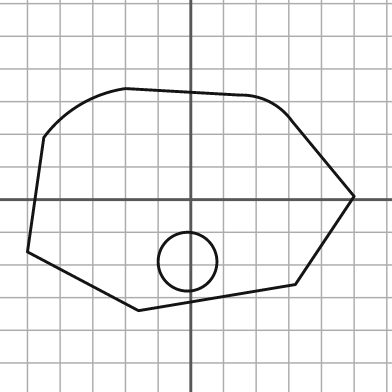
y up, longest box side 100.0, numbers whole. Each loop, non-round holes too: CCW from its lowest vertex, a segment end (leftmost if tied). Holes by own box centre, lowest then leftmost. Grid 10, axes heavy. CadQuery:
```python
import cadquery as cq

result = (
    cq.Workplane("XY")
    .moveTo(-16.0, -34.0)
    .lineTo(32.0, -26.0)
    .lineTo(50.0, 1.0)
    .lineTo(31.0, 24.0)
    .threePointArc((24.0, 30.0), (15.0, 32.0))
    .lineTo(-20.0, 34.0)
    .threePointArc((-34.0, 29.0), (-45.0, 19.0))
    .lineTo(-50.0, -16.0)
    .close()
    .moveTo(-1.0, -19.0)
    .circle(9.0)
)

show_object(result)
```